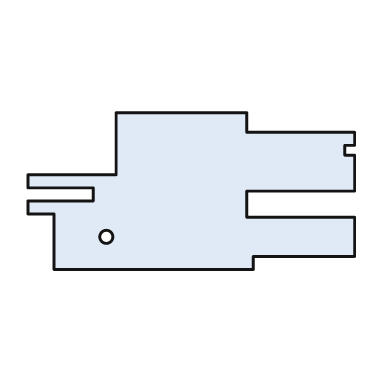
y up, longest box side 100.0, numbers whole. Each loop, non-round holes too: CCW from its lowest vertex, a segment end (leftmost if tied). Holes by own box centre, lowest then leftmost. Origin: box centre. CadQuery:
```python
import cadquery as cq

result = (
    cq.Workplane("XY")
    .moveTo(-42.0, -24.0)
    .lineTo(19.0, -24.0)
    .lineTo(19.0, -20.0)
    .lineTo(50.0, -20.0)
    .lineTo(50.0, -8.0)
    .lineTo(17.0, -8.0)
    .lineTo(17.0, 0.0)
    .lineTo(50.0, 0.0)
    .lineTo(50.0, 11.0)
    .lineTo(47.0, 11.0)
    .lineTo(47.0, 14.0)
    .lineTo(50.0, 14.0)
    .lineTo(50.0, 18.0)
    .lineTo(17.0, 18.0)
    .lineTo(17.0, 24.0)
    .lineTo(-23.0, 24.0)
    .lineTo(-23.0, 5.0)
    .lineTo(-50.0, 5.0)
    .lineTo(-50.0, 1.0)
    .lineTo(-30.0, 1.0)
    .lineTo(-30.0, -3.0)
    .lineTo(-50.0, -3.0)
    .lineTo(-50.0, -7.0)
    .lineTo(-42.0, -7.0)
    .close()
    .moveTo(-26.0, -14.0)
    .circle(2.0)
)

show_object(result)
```